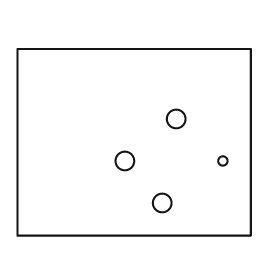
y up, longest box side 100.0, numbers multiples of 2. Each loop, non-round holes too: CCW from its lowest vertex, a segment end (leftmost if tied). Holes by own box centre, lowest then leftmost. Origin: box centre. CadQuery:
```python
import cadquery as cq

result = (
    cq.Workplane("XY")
    .moveTo(-50.0, -40.0)
    .lineTo(50.0, -40.0)
    .lineTo(50.0, 40.0)
    .lineTo(-50.0, 40.0)
    .close()
    .moveTo(12.0, -26.0)
    .circle(4.0)
    .moveTo(-4.0, -8.0)
    .circle(4.0)
    .moveTo(38.0, -8.0)
    .circle(2.0)
    .moveTo(18.0, 10.0)
    .circle(4.0)
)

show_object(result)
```